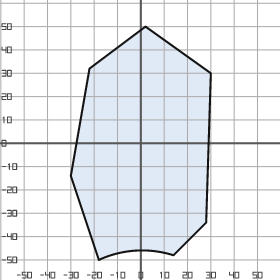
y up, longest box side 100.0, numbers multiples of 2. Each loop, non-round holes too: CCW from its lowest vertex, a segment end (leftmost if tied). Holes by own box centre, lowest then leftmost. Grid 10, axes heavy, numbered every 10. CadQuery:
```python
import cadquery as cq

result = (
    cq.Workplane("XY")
    .moveTo(-18.0, -50.0)
    .threePointArc((-2.0, -46.0), (14.0, -48.0))
    .lineTo(28.0, -34.0)
    .lineTo(30.0, 30.0)
    .lineTo(2.0, 50.0)
    .lineTo(-22.0, 32.0)
    .lineTo(-30.0, -14.0)
    .close()
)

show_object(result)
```